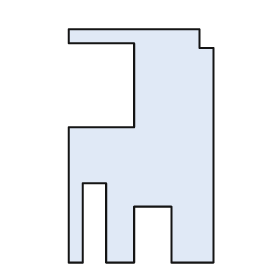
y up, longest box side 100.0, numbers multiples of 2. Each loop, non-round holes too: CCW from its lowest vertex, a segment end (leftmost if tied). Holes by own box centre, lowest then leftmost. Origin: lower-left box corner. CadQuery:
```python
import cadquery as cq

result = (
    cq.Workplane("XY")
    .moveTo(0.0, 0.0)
    .lineTo(6.0, 0.0)
    .lineTo(6.0, 34.0)
    .lineTo(16.0, 34.0)
    .lineTo(16.0, 0.0)
    .lineTo(28.0, 0.0)
    .lineTo(28.0, 24.0)
    .lineTo(44.0, 24.0)
    .lineTo(44.0, 0.0)
    .lineTo(62.0, 0.0)
    .lineTo(62.0, 92.0)
    .lineTo(56.0, 92.0)
    .lineTo(56.0, 100.0)
    .lineTo(0.0, 100.0)
    .lineTo(0.0, 94.0)
    .lineTo(28.0, 94.0)
    .lineTo(28.0, 58.0)
    .lineTo(0.0, 58.0)
    .close()
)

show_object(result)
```